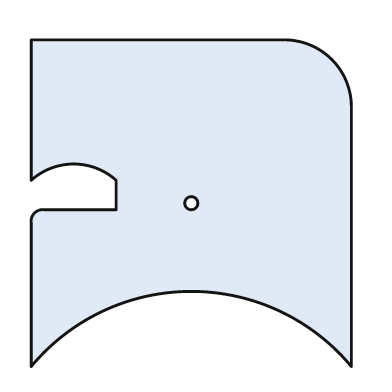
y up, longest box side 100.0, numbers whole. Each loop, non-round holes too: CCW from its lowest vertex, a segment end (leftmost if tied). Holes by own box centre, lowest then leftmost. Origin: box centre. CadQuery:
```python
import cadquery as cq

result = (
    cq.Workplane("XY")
    .moveTo(-49.0, -50.0)
    .threePointArc((0.0, -27.0), (49.0, -50.0))
    .lineTo(49.0, 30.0)
    .threePointArc((43.0, 44.0), (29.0, 50.0))
    .lineTo(-49.0, 50.0)
    .lineTo(-49.0, 7.0)
    .threePointArc((-36.0, 12.0), (-23.0, 7.0))
    .lineTo(-23.0, -2.0)
    .lineTo(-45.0, -2.0)
    .threePointArc((-48.0, -3.0), (-49.0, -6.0))
    .close()
    .moveTo(0.0, 0.0)
    .circle(2.0)
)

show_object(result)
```